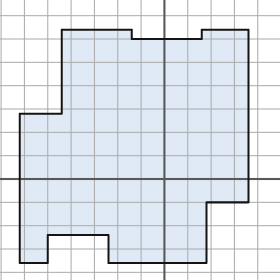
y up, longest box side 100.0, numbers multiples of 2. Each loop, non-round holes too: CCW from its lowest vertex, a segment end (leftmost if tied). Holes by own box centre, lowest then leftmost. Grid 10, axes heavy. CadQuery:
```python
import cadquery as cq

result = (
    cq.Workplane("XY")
    .moveTo(-62.0, -36.0)
    .lineTo(-50.0, -36.0)
    .lineTo(-50.0, -24.0)
    .lineTo(-24.0, -24.0)
    .lineTo(-24.0, -36.0)
    .lineTo(18.0, -36.0)
    .lineTo(18.0, -10.0)
    .lineTo(36.0, -10.0)
    .lineTo(36.0, 64.0)
    .lineTo(16.0, 64.0)
    .lineTo(16.0, 60.0)
    .lineTo(-14.0, 60.0)
    .lineTo(-14.0, 64.0)
    .lineTo(-44.0, 64.0)
    .lineTo(-44.0, 28.0)
    .lineTo(-62.0, 28.0)
    .close()
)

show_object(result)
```